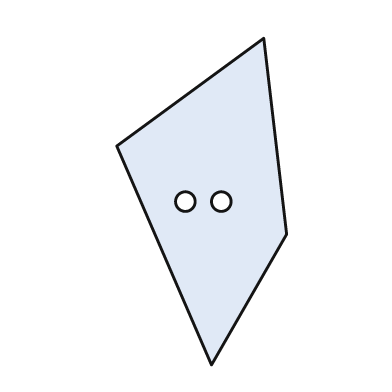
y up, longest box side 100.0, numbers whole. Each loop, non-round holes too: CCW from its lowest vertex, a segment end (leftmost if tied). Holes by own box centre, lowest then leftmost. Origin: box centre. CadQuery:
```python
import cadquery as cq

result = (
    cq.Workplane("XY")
    .moveTo(3.0, -50.0)
    .lineTo(26.0, -10.0)
    .lineTo(19.0, 50.0)
    .lineTo(-26.0, 17.0)
    .close()
    .moveTo(-5.0, 0.0)
    .circle(3.0)
    .moveTo(6.0, 0.0)
    .circle(3.0)
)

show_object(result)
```